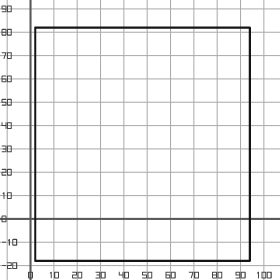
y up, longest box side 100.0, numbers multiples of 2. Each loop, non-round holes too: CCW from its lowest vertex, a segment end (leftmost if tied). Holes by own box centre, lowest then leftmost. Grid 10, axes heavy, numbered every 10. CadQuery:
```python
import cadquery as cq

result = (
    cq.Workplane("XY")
    .moveTo(2.0, -18.0)
    .lineTo(94.0, -18.0)
    .lineTo(94.0, 82.0)
    .lineTo(2.0, 82.0)
    .close()
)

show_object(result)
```